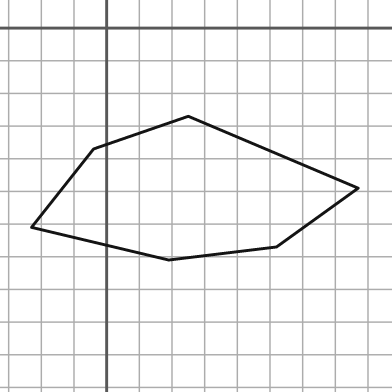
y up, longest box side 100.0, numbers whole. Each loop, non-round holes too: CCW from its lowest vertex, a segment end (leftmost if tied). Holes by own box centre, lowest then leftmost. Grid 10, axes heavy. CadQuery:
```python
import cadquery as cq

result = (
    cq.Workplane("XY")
    .moveTo(19.0, -71.0)
    .lineTo(52.0, -67.0)
    .lineTo(77.0, -49.0)
    .lineTo(25.0, -27.0)
    .lineTo(-4.0, -37.0)
    .lineTo(-23.0, -61.0)
    .close()
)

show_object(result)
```